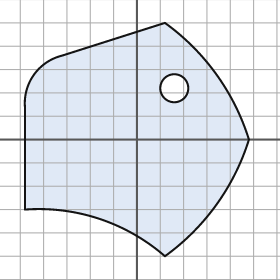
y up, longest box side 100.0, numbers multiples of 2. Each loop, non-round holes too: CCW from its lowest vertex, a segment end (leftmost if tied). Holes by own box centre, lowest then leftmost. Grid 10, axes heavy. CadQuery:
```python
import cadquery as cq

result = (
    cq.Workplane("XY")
    .moveTo(12.0, -50.0)
    .threePointArc((34.0, -28.0), (48.0, 0.0))
    .threePointArc((34.0, 28.0), (12.0, 50.0))
    .lineTo(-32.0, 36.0)
    .threePointArc((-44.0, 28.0), (-48.0, 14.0))
    .lineTo(-48.0, -30.0)
    .threePointArc((-16.0, -34.0), (12.0, -50.0))
    .close()
    .moveTo(16.0, 22.0)
    .circle(6.0)
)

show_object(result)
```